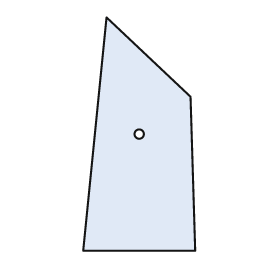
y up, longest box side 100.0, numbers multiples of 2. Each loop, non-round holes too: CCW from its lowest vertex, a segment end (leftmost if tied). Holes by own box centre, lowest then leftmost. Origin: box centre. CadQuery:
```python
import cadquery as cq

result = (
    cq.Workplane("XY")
    .moveTo(-24.0, -50.0)
    .lineTo(24.0, -50.0)
    .lineTo(22.0, 16.0)
    .lineTo(-14.0, 50.0)
    .close()
    .moveTo(0.0, 0.0)
    .circle(2.0)
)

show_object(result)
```